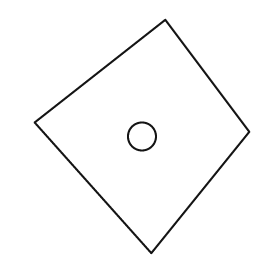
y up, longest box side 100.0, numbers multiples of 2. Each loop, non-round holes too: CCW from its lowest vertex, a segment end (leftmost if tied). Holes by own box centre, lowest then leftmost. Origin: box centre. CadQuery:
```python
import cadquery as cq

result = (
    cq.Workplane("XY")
    .moveTo(4.0, -50.0)
    .lineTo(46.0, 2.0)
    .lineTo(10.0, 50.0)
    .lineTo(-46.0, 6.0)
    .close()
    .moveTo(0.0, 0.0)
    .circle(6.0)
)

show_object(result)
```